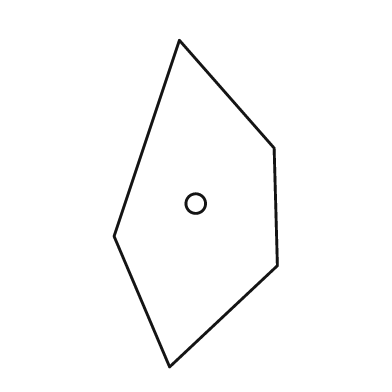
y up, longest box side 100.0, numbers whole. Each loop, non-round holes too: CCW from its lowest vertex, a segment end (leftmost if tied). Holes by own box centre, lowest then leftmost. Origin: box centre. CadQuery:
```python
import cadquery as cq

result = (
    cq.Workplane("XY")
    .moveTo(-8.0, -50.0)
    .lineTo(25.0, -19.0)
    .lineTo(24.0, 17.0)
    .lineTo(-5.0, 50.0)
    .lineTo(-25.0, -10.0)
    .close()
    .moveTo(0.0, 0.0)
    .circle(3.0)
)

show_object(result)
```